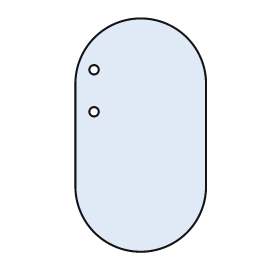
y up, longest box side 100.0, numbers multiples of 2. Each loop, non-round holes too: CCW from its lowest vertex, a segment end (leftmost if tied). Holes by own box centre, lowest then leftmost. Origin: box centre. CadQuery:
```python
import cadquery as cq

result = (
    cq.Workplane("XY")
    .moveTo(-28.0, -22.0)
    .threePointArc((0.0, -50.0), (28.0, -22.0))
    .lineTo(28.0, 22.0)
    .threePointArc((0.0, 50.0), (-28.0, 22.0))
    .close()
    .moveTo(-20.0, 10.0)
    .circle(2.0)
    .moveTo(-20.0, 28.0)
    .circle(2.0)
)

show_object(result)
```